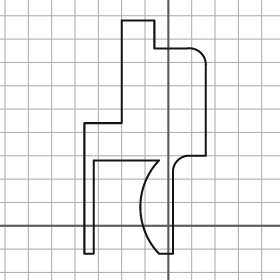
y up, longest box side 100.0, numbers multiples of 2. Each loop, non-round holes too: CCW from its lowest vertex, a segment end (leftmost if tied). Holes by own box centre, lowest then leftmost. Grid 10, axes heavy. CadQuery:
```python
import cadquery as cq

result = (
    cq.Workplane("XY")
    .moveTo(-36.0, -12.0)
    .lineTo(-32.0, -12.0)
    .lineTo(-32.0, 28.0)
    .lineTo(-4.0, 28.0)
    .threePointArc((-12.0, 8.0), (-4.0, -12.0))
    .lineTo(2.0, -12.0)
    .lineTo(2.0, 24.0)
    .threePointArc((4.0, 28.0), (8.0, 30.0))
    .lineTo(16.0, 30.0)
    .lineTo(16.0, 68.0)
    .threePointArc((14.0, 74.0), (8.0, 76.0))
    .lineTo(-6.0, 76.0)
    .lineTo(-6.0, 88.0)
    .lineTo(-20.0, 88.0)
    .lineTo(-20.0, 44.0)
    .lineTo(-36.0, 44.0)
    .close()
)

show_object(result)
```